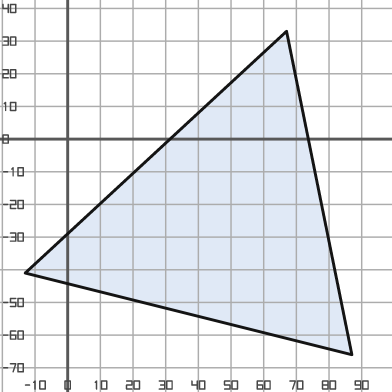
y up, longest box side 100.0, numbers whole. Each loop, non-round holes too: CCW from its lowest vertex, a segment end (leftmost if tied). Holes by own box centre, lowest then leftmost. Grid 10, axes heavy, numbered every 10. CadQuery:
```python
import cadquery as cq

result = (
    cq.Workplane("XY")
    .moveTo(87.0, -66.0)
    .lineTo(67.0, 33.0)
    .lineTo(-13.0, -41.0)
    .close()
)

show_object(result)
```